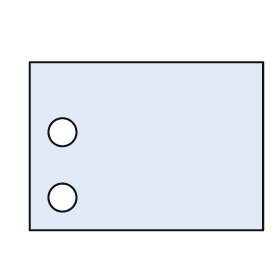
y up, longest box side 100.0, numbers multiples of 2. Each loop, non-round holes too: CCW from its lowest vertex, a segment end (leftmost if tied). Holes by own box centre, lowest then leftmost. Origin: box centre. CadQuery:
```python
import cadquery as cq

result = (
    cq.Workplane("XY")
    .moveTo(-50.0, -36.0)
    .lineTo(50.0, -36.0)
    .lineTo(50.0, 36.0)
    .lineTo(-50.0, 36.0)
    .close()
    .moveTo(-36.0, -22.0)
    .circle(6.0)
    .moveTo(-36.0, 6.0)
    .circle(6.0)
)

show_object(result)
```